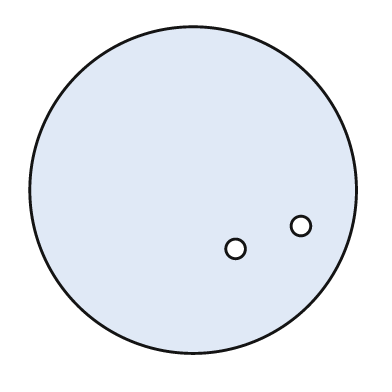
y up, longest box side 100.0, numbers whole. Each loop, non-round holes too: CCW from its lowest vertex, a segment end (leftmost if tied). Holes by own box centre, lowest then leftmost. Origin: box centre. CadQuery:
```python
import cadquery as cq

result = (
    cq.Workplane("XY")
    .moveTo(0.0, 0.0)
    .circle(50.0)
    .moveTo(13.0, -18.0)
    .circle(3.0)
    .moveTo(33.0, -11.0)
    .circle(3.0)
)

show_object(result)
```